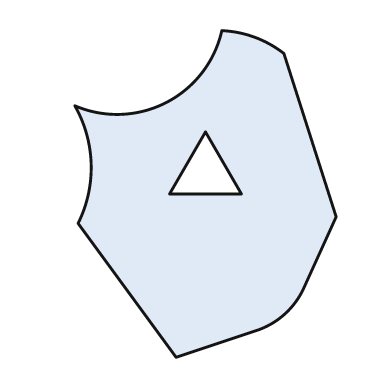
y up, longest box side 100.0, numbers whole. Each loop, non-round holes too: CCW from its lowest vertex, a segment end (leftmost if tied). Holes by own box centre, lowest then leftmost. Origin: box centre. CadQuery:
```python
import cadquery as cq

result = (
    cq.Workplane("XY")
    .moveTo(-9.0, -50.0)
    .lineTo(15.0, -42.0)
    .threePointArc((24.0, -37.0), (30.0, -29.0))
    .lineTo(40.0, -7.0)
    .lineTo(24.0, 43.0)
    .threePointArc((15.0, 48.0), (5.0, 50.0))
    .threePointArc((-12.0, 28.0), (-40.0, 27.0))
    .threePointArc((-35.0, 9.0), (-39.0, -9.0))
    .close()
    .moveTo(-11.0, 0.0)
    .lineTo(11.0, 0.0)
    .lineTo(0.0, 19.0)
    .close()
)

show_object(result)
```